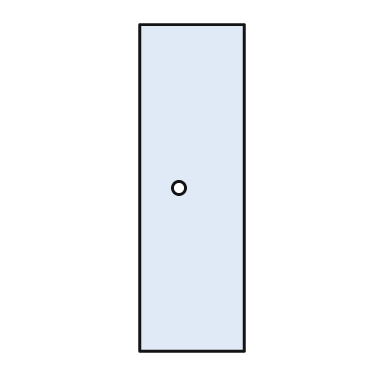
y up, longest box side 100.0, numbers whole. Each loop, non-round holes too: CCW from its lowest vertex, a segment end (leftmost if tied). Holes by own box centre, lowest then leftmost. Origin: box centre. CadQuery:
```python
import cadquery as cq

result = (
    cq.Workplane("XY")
    .moveTo(-16.0, -50.0)
    .lineTo(16.0, -50.0)
    .lineTo(16.0, 50.0)
    .lineTo(-16.0, 50.0)
    .close()
    .moveTo(-4.0, 0.0)
    .circle(2.0)
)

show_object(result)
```